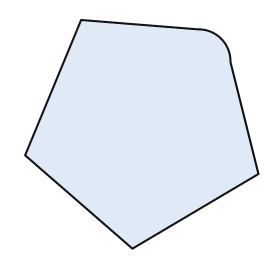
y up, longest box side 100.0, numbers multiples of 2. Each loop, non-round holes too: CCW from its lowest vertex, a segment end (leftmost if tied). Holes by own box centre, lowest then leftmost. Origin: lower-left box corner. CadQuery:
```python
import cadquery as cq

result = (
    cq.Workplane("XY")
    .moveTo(46.0, 0.0)
    .lineTo(100.0, 32.0)
    .lineTo(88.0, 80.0)
    .threePointArc((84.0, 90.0), (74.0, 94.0))
    .lineTo(24.0, 98.0)
    .lineTo(0.0, 40.0)
    .close()
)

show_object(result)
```